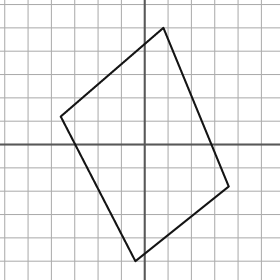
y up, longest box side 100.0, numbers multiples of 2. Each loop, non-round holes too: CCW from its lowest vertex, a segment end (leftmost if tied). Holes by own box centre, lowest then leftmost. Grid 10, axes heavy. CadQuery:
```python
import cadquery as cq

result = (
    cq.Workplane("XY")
    .moveTo(-4.0, -50.0)
    .lineTo(36.0, -18.0)
    .lineTo(8.0, 50.0)
    .lineTo(-36.0, 12.0)
    .close()
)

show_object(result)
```